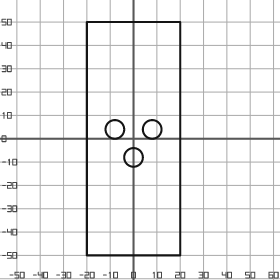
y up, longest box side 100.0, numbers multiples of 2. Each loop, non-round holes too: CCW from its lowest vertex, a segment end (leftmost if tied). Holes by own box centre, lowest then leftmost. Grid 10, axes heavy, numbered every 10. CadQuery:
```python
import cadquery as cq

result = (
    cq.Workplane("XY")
    .moveTo(-20.0, -50.0)
    .lineTo(20.0, -50.0)
    .lineTo(20.0, 50.0)
    .lineTo(-20.0, 50.0)
    .close()
    .moveTo(0.0, -8.0)
    .circle(4.0)
    .moveTo(-8.0, 4.0)
    .circle(4.0)
    .moveTo(8.0, 4.0)
    .circle(4.0)
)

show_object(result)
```